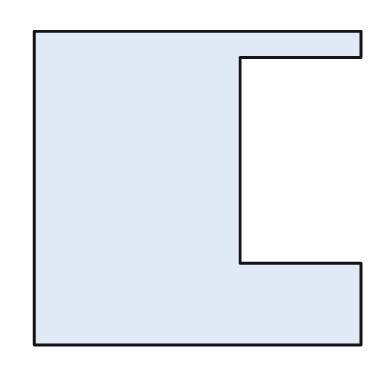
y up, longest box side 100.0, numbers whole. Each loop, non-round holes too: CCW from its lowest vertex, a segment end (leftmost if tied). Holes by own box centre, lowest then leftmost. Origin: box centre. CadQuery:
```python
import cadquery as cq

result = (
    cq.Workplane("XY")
    .moveTo(-50.0, -48.0)
    .lineTo(50.0, -48.0)
    .lineTo(50.0, -23.0)
    .lineTo(13.0, -23.0)
    .lineTo(13.0, 40.0)
    .lineTo(50.0, 40.0)
    .lineTo(50.0, 48.0)
    .lineTo(-50.0, 48.0)
    .close()
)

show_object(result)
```